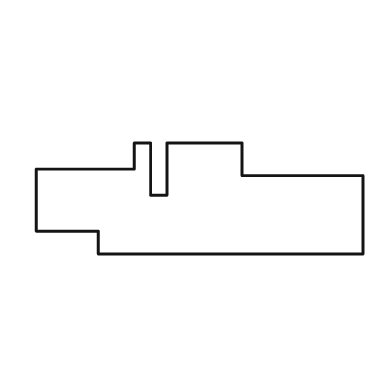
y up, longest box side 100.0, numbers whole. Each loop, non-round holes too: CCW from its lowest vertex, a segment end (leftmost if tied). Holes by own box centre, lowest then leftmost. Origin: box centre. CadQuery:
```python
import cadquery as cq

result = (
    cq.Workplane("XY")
    .moveTo(-31.0, -17.0)
    .lineTo(50.0, -17.0)
    .lineTo(50.0, 7.0)
    .lineTo(13.0, 7.0)
    .lineTo(13.0, 17.0)
    .lineTo(-10.0, 17.0)
    .lineTo(-10.0, 1.0)
    .lineTo(-15.0, 1.0)
    .lineTo(-15.0, 17.0)
    .lineTo(-20.0, 17.0)
    .lineTo(-20.0, 9.0)
    .lineTo(-50.0, 9.0)
    .lineTo(-50.0, -10.0)
    .lineTo(-31.0, -10.0)
    .close()
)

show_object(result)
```